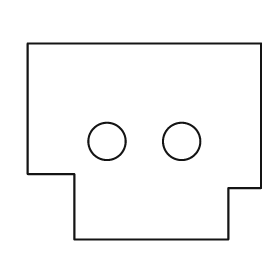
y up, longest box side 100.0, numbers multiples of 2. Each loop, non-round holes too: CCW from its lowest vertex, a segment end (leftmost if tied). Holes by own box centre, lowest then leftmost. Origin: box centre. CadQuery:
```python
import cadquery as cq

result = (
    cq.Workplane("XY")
    .moveTo(-30.0, -42.0)
    .lineTo(36.0, -42.0)
    .lineTo(36.0, -20.0)
    .lineTo(50.0, -20.0)
    .lineTo(50.0, 42.0)
    .lineTo(-50.0, 42.0)
    .lineTo(-50.0, -14.0)
    .lineTo(-30.0, -14.0)
    .close()
    .moveTo(-16.0, 0.0)
    .circle(8.0)
    .moveTo(16.0, 0.0)
    .circle(8.0)
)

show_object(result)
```